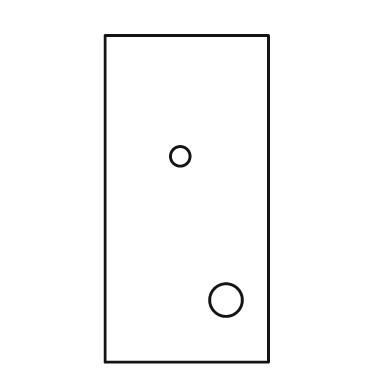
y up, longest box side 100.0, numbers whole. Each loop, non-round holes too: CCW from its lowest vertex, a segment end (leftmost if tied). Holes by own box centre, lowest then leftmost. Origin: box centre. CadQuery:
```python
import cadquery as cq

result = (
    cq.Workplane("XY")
    .moveTo(-25.0, -50.0)
    .lineTo(25.0, -50.0)
    .lineTo(25.0, 50.0)
    .lineTo(-25.0, 50.0)
    .close()
    .moveTo(12.0, -31.0)
    .circle(5.0)
    .moveTo(-2.0, 13.0)
    .circle(3.0)
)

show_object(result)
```